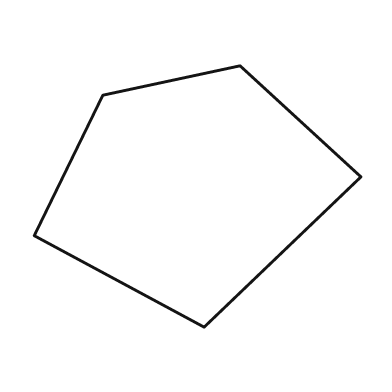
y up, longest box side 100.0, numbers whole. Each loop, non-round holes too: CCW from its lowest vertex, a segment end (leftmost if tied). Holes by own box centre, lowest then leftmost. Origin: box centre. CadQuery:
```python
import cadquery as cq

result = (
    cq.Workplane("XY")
    .moveTo(2.0, -40.0)
    .lineTo(50.0, 6.0)
    .lineTo(13.0, 40.0)
    .lineTo(-29.0, 31.0)
    .lineTo(-50.0, -12.0)
    .close()
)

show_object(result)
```